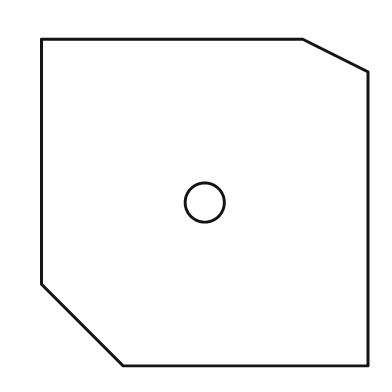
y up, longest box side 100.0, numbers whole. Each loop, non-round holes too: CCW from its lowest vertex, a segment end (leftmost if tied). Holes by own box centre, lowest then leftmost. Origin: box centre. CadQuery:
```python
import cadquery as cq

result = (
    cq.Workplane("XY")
    .moveTo(-25.0, -50.0)
    .lineTo(50.0, -50.0)
    .lineTo(50.0, 40.0)
    .lineTo(30.0, 50.0)
    .lineTo(-50.0, 50.0)
    .lineTo(-50.0, -25.0)
    .close()
    .moveTo(0.0, 0.0)
    .circle(6.0)
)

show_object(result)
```